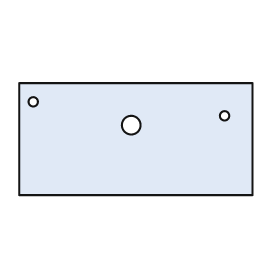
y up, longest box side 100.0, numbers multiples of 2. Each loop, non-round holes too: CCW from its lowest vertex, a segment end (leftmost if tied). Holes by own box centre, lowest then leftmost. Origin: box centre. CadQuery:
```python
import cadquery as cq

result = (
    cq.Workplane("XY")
    .moveTo(-50.0, -24.0)
    .lineTo(50.0, -24.0)
    .lineTo(50.0, 24.0)
    .lineTo(-50.0, 24.0)
    .close()
    .moveTo(-2.0, 6.0)
    .circle(4.0)
    .moveTo(38.0, 10.0)
    .circle(2.0)
    .moveTo(-44.0, 16.0)
    .circle(2.0)
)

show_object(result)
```